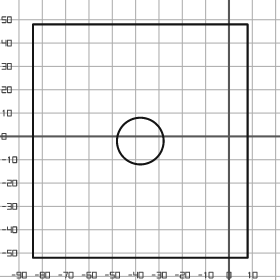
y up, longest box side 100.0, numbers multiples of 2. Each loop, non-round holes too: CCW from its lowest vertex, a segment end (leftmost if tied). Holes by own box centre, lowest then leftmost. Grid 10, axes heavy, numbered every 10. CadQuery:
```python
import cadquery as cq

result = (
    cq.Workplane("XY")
    .moveTo(-84.0, -52.0)
    .lineTo(8.0, -52.0)
    .lineTo(8.0, 48.0)
    .lineTo(-84.0, 48.0)
    .close()
    .moveTo(-38.0, -2.0)
    .circle(10.0)
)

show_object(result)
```